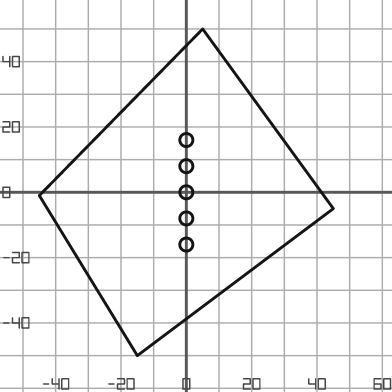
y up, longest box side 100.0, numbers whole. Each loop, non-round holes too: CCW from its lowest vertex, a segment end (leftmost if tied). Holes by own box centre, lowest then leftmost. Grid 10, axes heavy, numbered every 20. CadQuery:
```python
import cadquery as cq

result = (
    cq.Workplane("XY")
    .moveTo(-15.0, -50.0)
    .lineTo(45.0, -5.0)
    .lineTo(5.0, 50.0)
    .lineTo(-45.0, -1.0)
    .close()
    .moveTo(0.0, -16.0)
    .circle(2.0)
    .moveTo(0.0, -8.0)
    .circle(2.0)
    .moveTo(0.0, 0.0)
    .circle(2.0)
    .moveTo(0.0, 8.0)
    .circle(2.0)
    .moveTo(0.0, 16.0)
    .circle(2.0)
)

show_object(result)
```